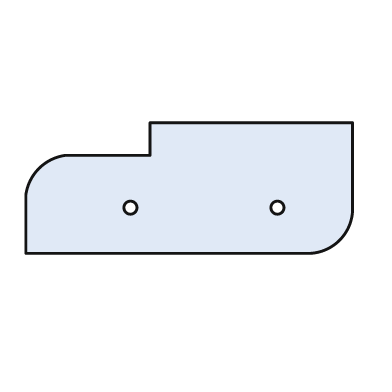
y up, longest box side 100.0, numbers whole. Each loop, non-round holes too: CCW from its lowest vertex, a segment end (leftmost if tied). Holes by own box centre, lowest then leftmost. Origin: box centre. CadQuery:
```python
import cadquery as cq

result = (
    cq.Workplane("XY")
    .moveTo(-50.0, -20.0)
    .lineTo(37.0, -20.0)
    .threePointArc((46.0, -16.0), (50.0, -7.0))
    .lineTo(50.0, 20.0)
    .lineTo(-12.0, 20.0)
    .lineTo(-12.0, 10.0)
    .lineTo(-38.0, 10.0)
    .threePointArc((-46.0, 6.0), (-50.0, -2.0))
    .close()
    .moveTo(-18.0, -6.0)
    .circle(2.0)
    .moveTo(27.0, -6.0)
    .circle(2.0)
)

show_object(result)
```